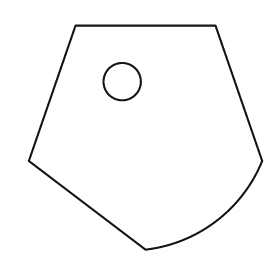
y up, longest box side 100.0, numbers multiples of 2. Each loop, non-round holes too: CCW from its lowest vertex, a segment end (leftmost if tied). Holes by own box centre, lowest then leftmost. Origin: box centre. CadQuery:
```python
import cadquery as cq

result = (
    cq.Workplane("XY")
    .moveTo(0.0, -48.0)
    .threePointArc((30.0, -36.0), (50.0, -10.0))
    .lineTo(30.0, 48.0)
    .lineTo(-30.0, 48.0)
    .lineTo(-50.0, -10.0)
    .close()
    .moveTo(-10.0, 24.0)
    .circle(8.0)
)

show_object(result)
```